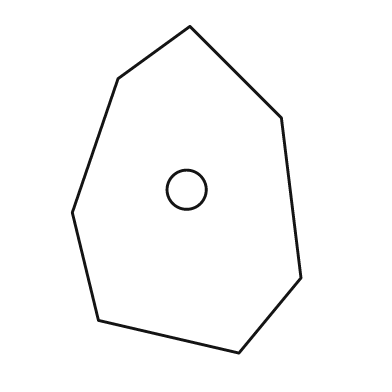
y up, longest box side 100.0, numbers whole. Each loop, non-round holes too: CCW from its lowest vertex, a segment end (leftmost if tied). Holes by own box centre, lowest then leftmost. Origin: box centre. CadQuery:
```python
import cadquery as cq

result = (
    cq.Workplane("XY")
    .moveTo(16.0, -50.0)
    .lineTo(35.0, -27.0)
    .lineTo(29.0, 22.0)
    .lineTo(1.0, 50.0)
    .lineTo(-21.0, 34.0)
    .lineTo(-35.0, -7.0)
    .lineTo(-27.0, -40.0)
    .close()
    .moveTo(0.0, 0.0)
    .circle(6.0)
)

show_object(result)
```